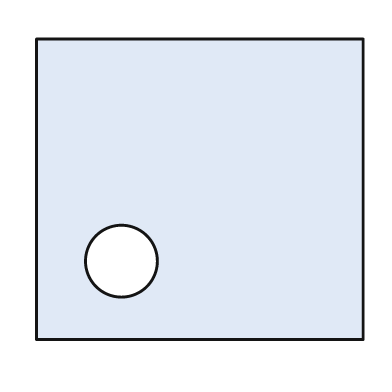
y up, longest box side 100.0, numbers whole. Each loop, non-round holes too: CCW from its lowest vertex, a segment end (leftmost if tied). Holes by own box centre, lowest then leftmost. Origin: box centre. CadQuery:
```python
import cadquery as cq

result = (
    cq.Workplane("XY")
    .moveTo(-50.0, -46.0)
    .lineTo(50.0, -46.0)
    .lineTo(50.0, 46.0)
    .lineTo(-50.0, 46.0)
    .close()
    .moveTo(-24.0, -22.0)
    .circle(11.0)
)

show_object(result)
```